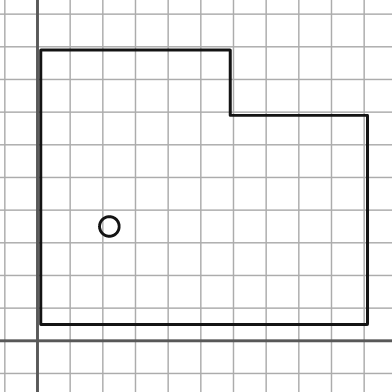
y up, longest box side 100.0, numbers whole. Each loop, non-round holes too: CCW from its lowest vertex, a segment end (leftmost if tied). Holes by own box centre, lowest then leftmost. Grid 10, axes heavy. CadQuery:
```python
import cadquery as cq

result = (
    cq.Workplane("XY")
    .moveTo(1.0, 5.0)
    .lineTo(101.0, 5.0)
    .lineTo(101.0, 69.0)
    .lineTo(59.0, 69.0)
    .lineTo(59.0, 89.0)
    .lineTo(1.0, 89.0)
    .close()
    .moveTo(22.0, 35.0)
    .circle(3.0)
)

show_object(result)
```